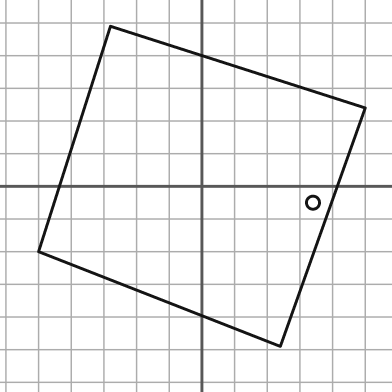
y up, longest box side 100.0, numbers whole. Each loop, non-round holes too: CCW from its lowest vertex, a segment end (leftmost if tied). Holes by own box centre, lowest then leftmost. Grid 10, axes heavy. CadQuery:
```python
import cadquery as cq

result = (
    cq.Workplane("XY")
    .moveTo(24.0, -49.0)
    .lineTo(50.0, 24.0)
    .lineTo(-28.0, 49.0)
    .lineTo(-50.0, -20.0)
    .close()
    .moveTo(34.0, -5.0)
    .circle(2.0)
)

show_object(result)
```